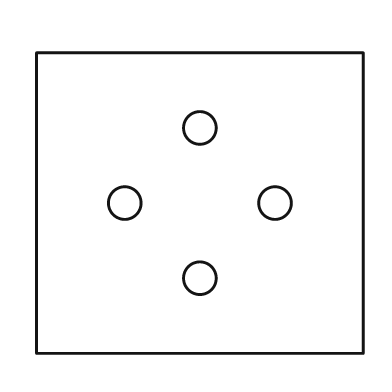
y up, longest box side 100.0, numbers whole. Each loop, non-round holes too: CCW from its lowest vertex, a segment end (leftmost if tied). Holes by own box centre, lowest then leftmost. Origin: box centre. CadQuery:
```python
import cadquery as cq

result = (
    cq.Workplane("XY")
    .moveTo(-50.0, -46.0)
    .lineTo(50.0, -46.0)
    .lineTo(50.0, 46.0)
    .lineTo(-50.0, 46.0)
    .close()
    .moveTo(0.0, -23.0)
    .circle(5.0)
    .moveTo(-23.0, 0.0)
    .circle(5.0)
    .moveTo(23.0, 0.0)
    .circle(5.0)
    .moveTo(0.0, 23.0)
    .circle(5.0)
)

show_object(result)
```